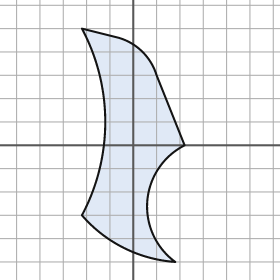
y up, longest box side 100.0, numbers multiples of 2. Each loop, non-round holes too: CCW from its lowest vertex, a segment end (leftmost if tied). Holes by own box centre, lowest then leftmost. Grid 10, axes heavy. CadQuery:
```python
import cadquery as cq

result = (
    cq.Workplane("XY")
    .moveTo(18.0, -50.0)
    .threePointArc((6.0, -24.0), (22.0, 0.0))
    .lineTo(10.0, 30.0)
    .threePointArc((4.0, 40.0), (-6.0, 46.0))
    .lineTo(-22.0, 50.0)
    .threePointArc((-12.0, 10.0), (-22.0, -30.0))
    .threePointArc((-4.0, -44.0), (18.0, -50.0))
    .close()
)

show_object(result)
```